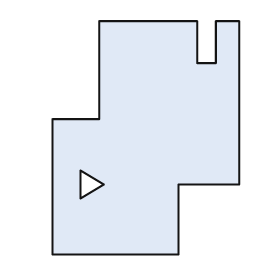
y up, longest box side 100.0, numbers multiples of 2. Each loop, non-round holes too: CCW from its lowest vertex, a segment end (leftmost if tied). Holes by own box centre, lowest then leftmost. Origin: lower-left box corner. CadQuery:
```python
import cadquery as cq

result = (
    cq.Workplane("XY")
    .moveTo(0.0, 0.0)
    .lineTo(54.0, 0.0)
    .lineTo(54.0, 30.0)
    .lineTo(80.0, 30.0)
    .lineTo(80.0, 100.0)
    .lineTo(70.0, 100.0)
    .lineTo(70.0, 82.0)
    .lineTo(62.0, 82.0)
    .lineTo(62.0, 100.0)
    .lineTo(20.0, 100.0)
    .lineTo(20.0, 58.0)
    .lineTo(0.0, 58.0)
    .close()
    .moveTo(12.0, 24.0)
    .lineTo(22.0, 30.0)
    .lineTo(12.0, 36.0)
    .close()
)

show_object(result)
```